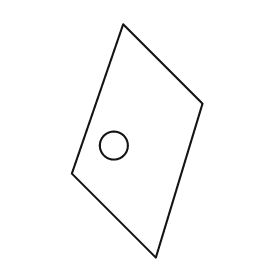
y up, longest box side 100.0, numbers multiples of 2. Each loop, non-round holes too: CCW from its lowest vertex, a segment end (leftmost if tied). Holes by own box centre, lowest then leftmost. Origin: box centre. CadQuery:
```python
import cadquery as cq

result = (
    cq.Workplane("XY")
    .moveTo(8.0, -50.0)
    .lineTo(28.0, 16.0)
    .lineTo(-6.0, 50.0)
    .lineTo(-28.0, -14.0)
    .close()
    .moveTo(-10.0, -2.0)
    .circle(6.0)
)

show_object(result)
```